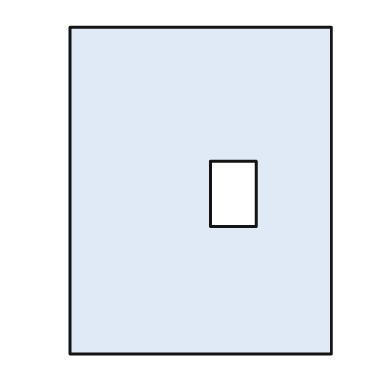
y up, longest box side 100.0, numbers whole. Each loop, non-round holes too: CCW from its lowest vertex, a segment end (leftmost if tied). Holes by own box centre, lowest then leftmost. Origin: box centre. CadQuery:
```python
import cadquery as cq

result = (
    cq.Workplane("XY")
    .moveTo(-40.0, -50.0)
    .lineTo(40.0, -50.0)
    .lineTo(40.0, 50.0)
    .lineTo(-40.0, 50.0)
    .close()
    .moveTo(3.0, -11.0)
    .lineTo(17.0, -11.0)
    .lineTo(17.0, 9.0)
    .lineTo(3.0, 9.0)
    .close()
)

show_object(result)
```